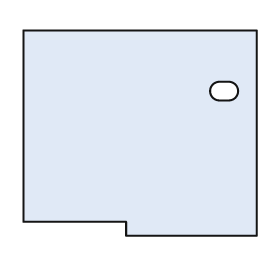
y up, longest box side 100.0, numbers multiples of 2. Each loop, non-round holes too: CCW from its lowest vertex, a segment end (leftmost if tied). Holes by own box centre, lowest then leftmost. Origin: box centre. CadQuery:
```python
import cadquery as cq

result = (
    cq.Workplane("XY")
    .moveTo(-6.0, -44.0)
    .lineTo(50.0, -44.0)
    .lineTo(50.0, 44.0)
    .lineTo(-50.0, 44.0)
    .lineTo(-50.0, -38.0)
    .lineTo(-6.0, -38.0)
    .close()
    .moveTo(34.0, 14.0)
    .lineTo(38.0, 14.0)
    .threePointArc((42.0, 18.0), (38.0, 22.0))
    .lineTo(34.0, 22.0)
    .threePointArc((30.0, 18.0), (34.0, 14.0))
    .close()
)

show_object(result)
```